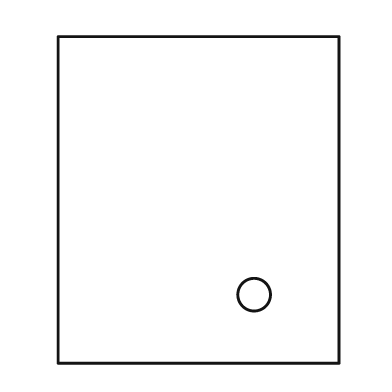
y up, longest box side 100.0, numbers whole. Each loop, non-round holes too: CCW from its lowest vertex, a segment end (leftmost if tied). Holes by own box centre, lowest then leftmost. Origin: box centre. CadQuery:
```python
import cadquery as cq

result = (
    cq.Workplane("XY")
    .moveTo(-43.0, -50.0)
    .lineTo(43.0, -50.0)
    .lineTo(43.0, 50.0)
    .lineTo(-43.0, 50.0)
    .close()
    .moveTo(17.0, -29.0)
    .circle(5.0)
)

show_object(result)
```